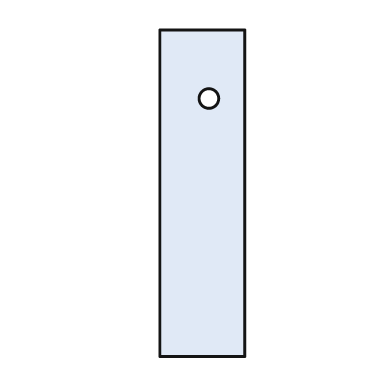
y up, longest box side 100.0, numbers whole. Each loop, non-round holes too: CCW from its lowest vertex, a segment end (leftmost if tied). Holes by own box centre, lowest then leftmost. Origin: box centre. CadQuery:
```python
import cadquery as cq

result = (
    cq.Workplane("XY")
    .moveTo(-13.0, -50.0)
    .lineTo(13.0, -50.0)
    .lineTo(13.0, 50.0)
    .lineTo(-13.0, 50.0)
    .close()
    .moveTo(2.0, 29.0)
    .circle(3.0)
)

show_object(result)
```